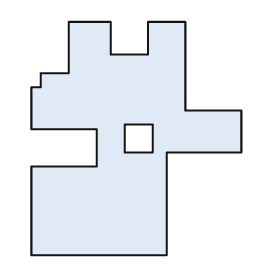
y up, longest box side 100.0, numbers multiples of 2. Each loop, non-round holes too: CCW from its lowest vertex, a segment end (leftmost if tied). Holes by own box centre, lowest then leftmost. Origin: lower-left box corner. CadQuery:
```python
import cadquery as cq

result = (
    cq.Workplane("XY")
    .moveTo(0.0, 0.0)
    .lineTo(58.0, 0.0)
    .lineTo(58.0, 44.0)
    .lineTo(90.0, 44.0)
    .lineTo(90.0, 62.0)
    .lineTo(66.0, 62.0)
    .lineTo(66.0, 100.0)
    .lineTo(50.0, 100.0)
    .lineTo(50.0, 86.0)
    .lineTo(34.0, 86.0)
    .lineTo(34.0, 100.0)
    .lineTo(16.0, 100.0)
    .lineTo(16.0, 78.0)
    .lineTo(4.0, 78.0)
    .lineTo(4.0, 72.0)
    .lineTo(0.0, 72.0)
    .lineTo(0.0, 54.0)
    .lineTo(28.0, 54.0)
    .lineTo(28.0, 38.0)
    .lineTo(0.0, 38.0)
    .close()
    .moveTo(40.0, 44.0)
    .lineTo(52.0, 44.0)
    .lineTo(52.0, 56.0)
    .lineTo(40.0, 56.0)
    .close()
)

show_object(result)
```